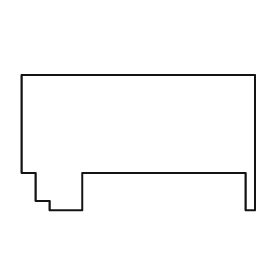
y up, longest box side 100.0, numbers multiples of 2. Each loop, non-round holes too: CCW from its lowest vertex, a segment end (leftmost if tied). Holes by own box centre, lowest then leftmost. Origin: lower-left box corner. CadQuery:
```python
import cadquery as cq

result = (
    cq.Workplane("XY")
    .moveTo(12.0, 0.0)
    .lineTo(26.0, 0.0)
    .lineTo(26.0, 16.0)
    .lineTo(96.0, 16.0)
    .lineTo(96.0, 0.0)
    .lineTo(100.0, 0.0)
    .lineTo(100.0, 58.0)
    .lineTo(0.0, 58.0)
    .lineTo(0.0, 16.0)
    .lineTo(6.0, 16.0)
    .lineTo(6.0, 4.0)
    .lineTo(12.0, 4.0)
    .close()
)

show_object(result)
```